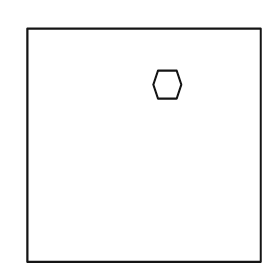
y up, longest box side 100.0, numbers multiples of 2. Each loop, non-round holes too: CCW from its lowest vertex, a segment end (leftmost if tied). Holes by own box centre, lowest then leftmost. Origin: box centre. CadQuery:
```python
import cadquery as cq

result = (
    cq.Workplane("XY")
    .moveTo(-50.0, -50.0)
    .lineTo(50.0, -50.0)
    .lineTo(50.0, 50.0)
    .lineTo(-50.0, 50.0)
    .close()
    .moveTo(6.0, 20.0)
    .lineTo(14.0, 20.0)
    .lineTo(16.0, 26.0)
    .lineTo(14.0, 32.0)
    .lineTo(6.0, 32.0)
    .lineTo(4.0, 26.0)
    .close()
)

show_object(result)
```